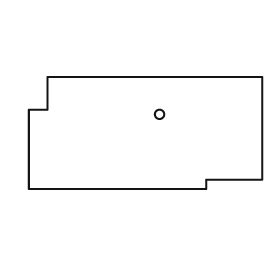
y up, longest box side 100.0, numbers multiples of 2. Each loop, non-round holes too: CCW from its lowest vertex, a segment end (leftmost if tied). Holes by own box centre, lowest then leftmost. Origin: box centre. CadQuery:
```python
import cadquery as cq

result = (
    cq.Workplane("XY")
    .moveTo(-50.0, -24.0)
    .lineTo(26.0, -24.0)
    .lineTo(26.0, -20.0)
    .lineTo(50.0, -20.0)
    .lineTo(50.0, 24.0)
    .lineTo(-42.0, 24.0)
    .lineTo(-42.0, 10.0)
    .lineTo(-50.0, 10.0)
    .close()
    .moveTo(6.0, 8.0)
    .circle(2.0)
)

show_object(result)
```